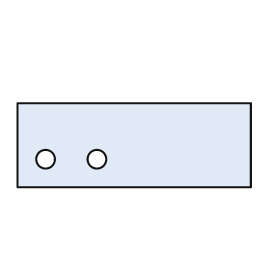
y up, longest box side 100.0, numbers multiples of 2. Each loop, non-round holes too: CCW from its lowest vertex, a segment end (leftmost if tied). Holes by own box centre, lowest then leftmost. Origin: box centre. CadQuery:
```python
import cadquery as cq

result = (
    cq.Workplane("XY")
    .moveTo(-50.0, -18.0)
    .lineTo(50.0, -18.0)
    .lineTo(50.0, 18.0)
    .lineTo(-50.0, 18.0)
    .close()
    .moveTo(-38.0, -6.0)
    .circle(4.0)
    .moveTo(-16.0, -6.0)
    .circle(4.0)
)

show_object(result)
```